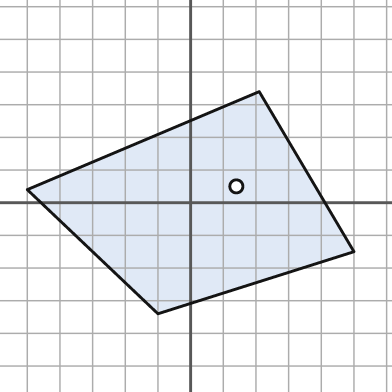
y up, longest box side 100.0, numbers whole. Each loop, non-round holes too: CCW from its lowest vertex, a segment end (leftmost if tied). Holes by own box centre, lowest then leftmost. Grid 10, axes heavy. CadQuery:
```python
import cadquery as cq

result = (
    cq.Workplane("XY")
    .moveTo(-10.0, -34.0)
    .lineTo(50.0, -15.0)
    .lineTo(21.0, 34.0)
    .lineTo(-50.0, 4.0)
    .close()
    .moveTo(14.0, 5.0)
    .circle(2.0)
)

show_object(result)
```